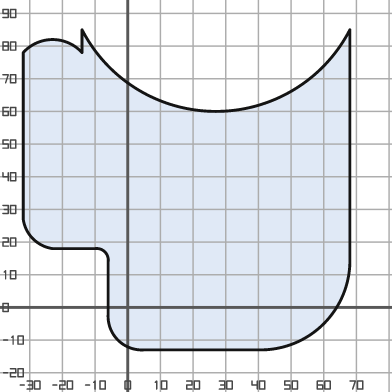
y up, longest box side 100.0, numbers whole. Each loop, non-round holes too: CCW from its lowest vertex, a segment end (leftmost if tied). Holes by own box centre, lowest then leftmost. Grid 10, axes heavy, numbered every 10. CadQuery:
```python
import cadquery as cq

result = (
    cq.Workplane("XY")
    .moveTo(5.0, -13.0)
    .lineTo(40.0, -13.0)
    .threePointArc((60.0, -5.0), (68.0, 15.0))
    .lineTo(68.0, 85.0)
    .threePointArc((27.0, 60.0), (-14.0, 85.0))
    .lineTo(-14.0, 78.0)
    .threePointArc((-23.0, 82.0), (-32.0, 78.0))
    .lineTo(-32.0, 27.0)
    .threePointArc((-29.0, 21.0), (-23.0, 18.0))
    .lineTo(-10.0, 18.0)
    .threePointArc((-7.0, 17.0), (-6.0, 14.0))
    .lineTo(-6.0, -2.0)
    .threePointArc((-3.0, -10.0), (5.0, -13.0))
    .close()
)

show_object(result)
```